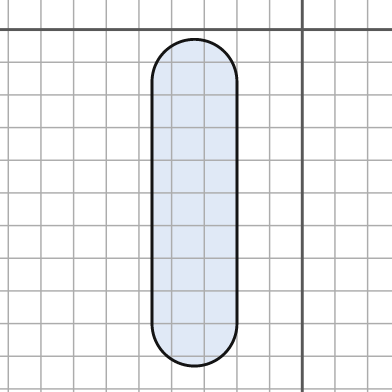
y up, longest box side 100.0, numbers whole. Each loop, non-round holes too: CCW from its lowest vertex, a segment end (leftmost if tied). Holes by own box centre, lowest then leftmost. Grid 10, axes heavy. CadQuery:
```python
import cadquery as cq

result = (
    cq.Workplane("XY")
    .moveTo(-46.0, -90.0)
    .threePointArc((-33.0, -103.0), (-20.0, -90.0))
    .lineTo(-20.0, -16.0)
    .threePointArc((-33.0, -3.0), (-46.0, -16.0))
    .close()
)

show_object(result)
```